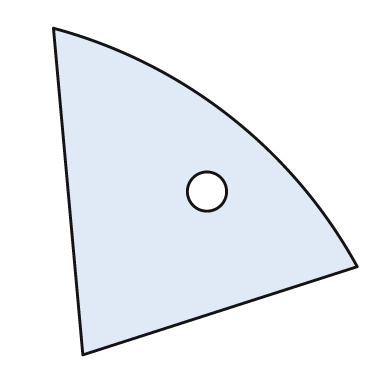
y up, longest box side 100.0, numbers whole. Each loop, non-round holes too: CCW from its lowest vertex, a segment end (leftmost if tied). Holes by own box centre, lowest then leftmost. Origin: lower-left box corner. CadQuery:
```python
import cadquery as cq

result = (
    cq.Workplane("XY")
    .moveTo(9.0, 0.0)
    .lineTo(93.0, 27.0)
    .threePointArc((54.0, 73.0), (0.0, 100.0))
    .close()
    .moveTo(47.0, 50.0)
    .circle(6.0)
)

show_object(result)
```